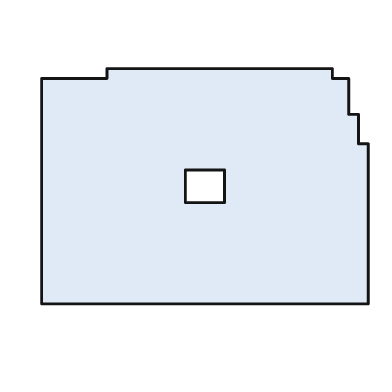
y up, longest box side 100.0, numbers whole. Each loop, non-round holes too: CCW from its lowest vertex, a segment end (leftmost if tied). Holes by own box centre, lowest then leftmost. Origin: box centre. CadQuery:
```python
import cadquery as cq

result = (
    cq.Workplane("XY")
    .moveTo(-50.0, -36.0)
    .lineTo(50.0, -36.0)
    .lineTo(50.0, 13.0)
    .lineTo(47.0, 13.0)
    .lineTo(47.0, 22.0)
    .lineTo(44.0, 22.0)
    .lineTo(44.0, 33.0)
    .lineTo(39.0, 33.0)
    .lineTo(39.0, 36.0)
    .lineTo(-30.0, 36.0)
    .lineTo(-30.0, 33.0)
    .lineTo(-50.0, 33.0)
    .close()
    .moveTo(-6.0, -5.0)
    .lineTo(6.0, -5.0)
    .lineTo(6.0, 5.0)
    .lineTo(-6.0, 5.0)
    .close()
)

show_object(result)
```